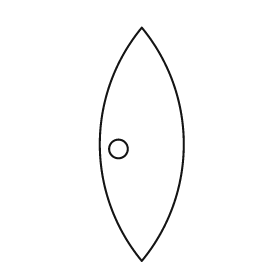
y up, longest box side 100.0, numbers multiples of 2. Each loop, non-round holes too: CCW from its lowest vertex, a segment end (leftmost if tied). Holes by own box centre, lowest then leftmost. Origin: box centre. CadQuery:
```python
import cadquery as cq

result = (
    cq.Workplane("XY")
    .moveTo(0.0, -50.0)
    .threePointArc((18.0, 0.0), (0.0, 50.0))
    .threePointArc((-18.0, 0.0), (0.0, -50.0))
    .close()
    .moveTo(-10.0, -2.0)
    .circle(4.0)
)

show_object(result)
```